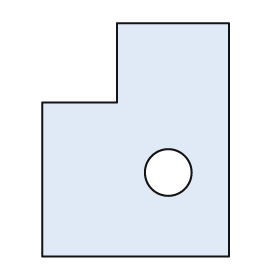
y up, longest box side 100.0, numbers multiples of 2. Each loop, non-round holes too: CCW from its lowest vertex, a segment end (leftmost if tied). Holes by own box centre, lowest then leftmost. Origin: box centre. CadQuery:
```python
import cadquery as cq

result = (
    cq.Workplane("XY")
    .moveTo(-40.0, -50.0)
    .lineTo(40.0, -50.0)
    .lineTo(40.0, 50.0)
    .lineTo(-8.0, 50.0)
    .lineTo(-8.0, 16.0)
    .lineTo(-40.0, 16.0)
    .close()
    .moveTo(14.0, -14.0)
    .circle(10.0)
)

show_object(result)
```